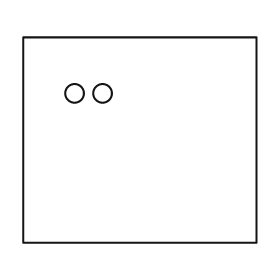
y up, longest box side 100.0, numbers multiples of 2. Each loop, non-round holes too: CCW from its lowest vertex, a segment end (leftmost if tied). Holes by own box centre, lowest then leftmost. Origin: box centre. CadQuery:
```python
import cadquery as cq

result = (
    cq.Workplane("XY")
    .moveTo(-50.0, -44.0)
    .lineTo(50.0, -44.0)
    .lineTo(50.0, 44.0)
    .lineTo(-50.0, 44.0)
    .close()
    .moveTo(-28.0, 20.0)
    .circle(4.0)
    .moveTo(-16.0, 20.0)
    .circle(4.0)
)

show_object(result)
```